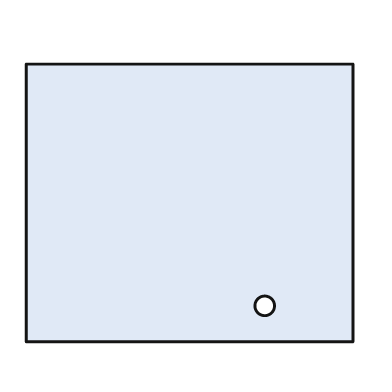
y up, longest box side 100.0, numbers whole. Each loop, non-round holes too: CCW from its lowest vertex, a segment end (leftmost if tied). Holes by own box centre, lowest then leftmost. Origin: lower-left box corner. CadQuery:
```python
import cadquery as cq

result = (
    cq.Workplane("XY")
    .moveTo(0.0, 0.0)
    .lineTo(100.0, 0.0)
    .lineTo(100.0, 85.0)
    .lineTo(0.0, 85.0)
    .close()
    .moveTo(73.0, 11.0)
    .circle(3.0)
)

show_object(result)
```